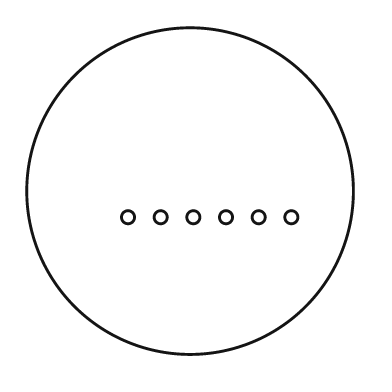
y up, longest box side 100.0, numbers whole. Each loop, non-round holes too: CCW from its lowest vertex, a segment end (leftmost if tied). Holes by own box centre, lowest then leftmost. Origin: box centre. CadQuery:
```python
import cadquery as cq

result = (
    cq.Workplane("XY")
    .moveTo(0.0, 0.0)
    .circle(50.0)
    .moveTo(-19.0, -8.0)
    .circle(2.0)
    .moveTo(-9.0, -8.0)
    .circle(2.0)
    .moveTo(1.0, -8.0)
    .circle(2.0)
    .moveTo(11.0, -8.0)
    .circle(2.0)
    .moveTo(21.0, -8.0)
    .circle(2.0)
    .moveTo(31.0, -8.0)
    .circle(2.0)
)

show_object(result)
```